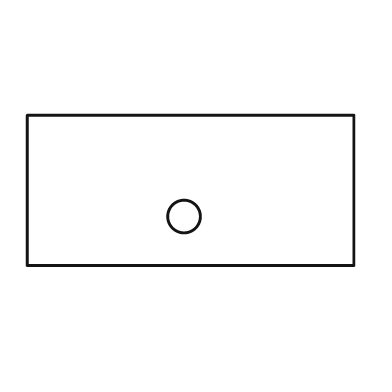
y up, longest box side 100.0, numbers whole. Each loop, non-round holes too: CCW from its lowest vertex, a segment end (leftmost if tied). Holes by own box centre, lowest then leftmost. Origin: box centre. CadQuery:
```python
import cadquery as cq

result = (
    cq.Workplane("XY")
    .moveTo(-50.0, -23.0)
    .lineTo(50.0, -23.0)
    .lineTo(50.0, 23.0)
    .lineTo(-50.0, 23.0)
    .close()
    .moveTo(-2.0, -8.0)
    .circle(5.0)
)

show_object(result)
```